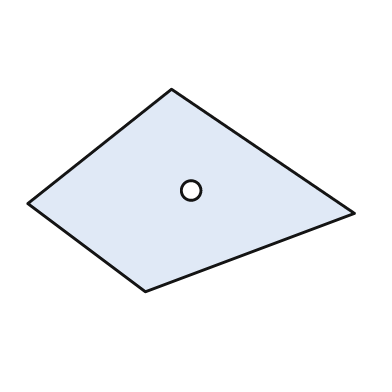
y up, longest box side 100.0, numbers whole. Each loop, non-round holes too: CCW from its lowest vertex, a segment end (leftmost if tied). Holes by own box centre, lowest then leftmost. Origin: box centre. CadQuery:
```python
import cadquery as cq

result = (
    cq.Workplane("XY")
    .moveTo(-14.0, -31.0)
    .lineTo(50.0, -7.0)
    .lineTo(-6.0, 31.0)
    .lineTo(-50.0, -4.0)
    .close()
    .moveTo(0.0, 0.0)
    .circle(3.0)
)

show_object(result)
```